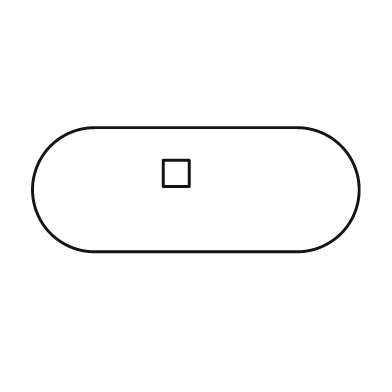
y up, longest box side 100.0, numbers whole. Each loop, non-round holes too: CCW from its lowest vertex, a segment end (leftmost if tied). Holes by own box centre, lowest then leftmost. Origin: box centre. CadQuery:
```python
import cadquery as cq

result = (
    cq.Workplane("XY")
    .moveTo(-31.0, -19.0)
    .lineTo(31.0, -19.0)
    .threePointArc((50.0, 0.0), (31.0, 19.0))
    .lineTo(-31.0, 19.0)
    .threePointArc((-50.0, 0.0), (-31.0, -19.0))
    .close()
    .moveTo(-10.0, 1.0)
    .lineTo(-2.0, 1.0)
    .lineTo(-2.0, 9.0)
    .lineTo(-10.0, 9.0)
    .close()
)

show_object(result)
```